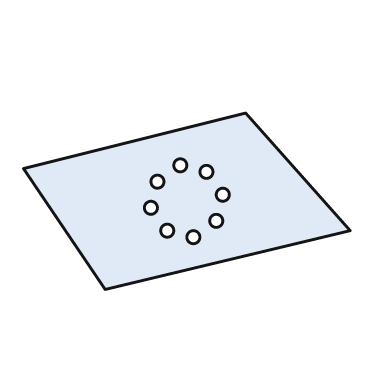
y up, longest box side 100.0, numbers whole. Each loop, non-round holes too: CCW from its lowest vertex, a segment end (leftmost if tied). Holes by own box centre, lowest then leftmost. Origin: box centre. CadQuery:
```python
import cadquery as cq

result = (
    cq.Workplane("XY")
    .moveTo(-25.0, -27.0)
    .lineTo(50.0, -9.0)
    .lineTo(18.0, 27.0)
    .lineTo(-50.0, 10.0)
    .close()
    .moveTo(2.0, -11.0)
    .circle(2.0)
    .moveTo(-6.0, -9.0)
    .circle(2.0)
    .moveTo(9.0, -6.0)
    .circle(2.0)
    .moveTo(-11.0, -2.0)
    .circle(2.0)
    .moveTo(11.0, 2.0)
    .circle(2.0)
    .moveTo(-9.0, 6.0)
    .circle(2.0)
    .moveTo(6.0, 9.0)
    .circle(2.0)
    .moveTo(-2.0, 11.0)
    .circle(2.0)
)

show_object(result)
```